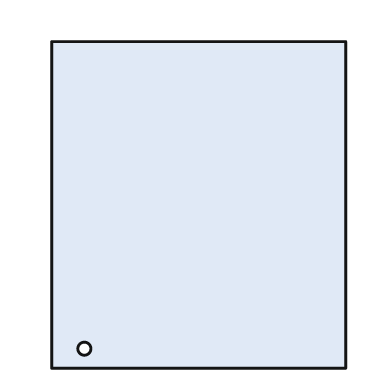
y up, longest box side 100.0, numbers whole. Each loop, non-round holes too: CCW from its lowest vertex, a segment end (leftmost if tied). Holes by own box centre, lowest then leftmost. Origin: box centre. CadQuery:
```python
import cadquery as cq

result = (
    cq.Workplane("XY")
    .moveTo(-45.0, -50.0)
    .lineTo(45.0, -50.0)
    .lineTo(45.0, 50.0)
    .lineTo(-45.0, 50.0)
    .close()
    .moveTo(-35.0, -44.0)
    .circle(2.0)
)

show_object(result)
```